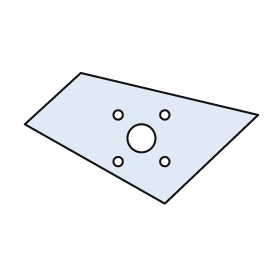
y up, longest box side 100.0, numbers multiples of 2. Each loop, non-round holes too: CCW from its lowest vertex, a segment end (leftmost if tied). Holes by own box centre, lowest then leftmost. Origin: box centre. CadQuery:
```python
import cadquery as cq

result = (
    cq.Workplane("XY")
    .moveTo(10.0, -28.0)
    .lineTo(50.0, 10.0)
    .lineTo(-26.0, 28.0)
    .lineTo(-50.0, 6.0)
    .close()
    .moveTo(-10.0, -10.0)
    .circle(2.0)
    .moveTo(10.0, -10.0)
    .circle(2.0)
    .moveTo(0.0, 0.0)
    .circle(6.0)
    .moveTo(-10.0, 10.0)
    .circle(2.0)
    .moveTo(10.0, 10.0)
    .circle(2.0)
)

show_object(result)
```